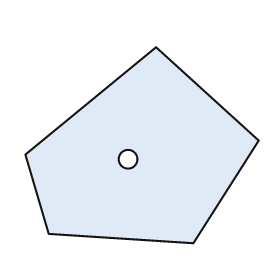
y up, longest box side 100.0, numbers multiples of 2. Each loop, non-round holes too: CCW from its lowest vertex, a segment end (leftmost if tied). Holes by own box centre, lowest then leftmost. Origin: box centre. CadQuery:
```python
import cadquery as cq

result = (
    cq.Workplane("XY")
    .moveTo(22.0, -42.0)
    .lineTo(50.0, 2.0)
    .lineTo(6.0, 42.0)
    .lineTo(-50.0, -4.0)
    .lineTo(-40.0, -38.0)
    .close()
    .moveTo(-6.0, -6.0)
    .circle(4.0)
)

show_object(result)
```